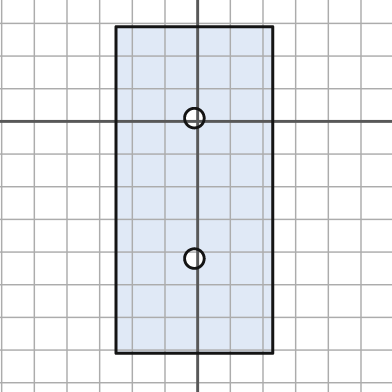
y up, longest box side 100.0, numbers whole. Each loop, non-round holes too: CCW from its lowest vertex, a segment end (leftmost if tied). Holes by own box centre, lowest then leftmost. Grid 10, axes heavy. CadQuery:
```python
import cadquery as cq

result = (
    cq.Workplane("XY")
    .moveTo(-25.0, -71.0)
    .lineTo(23.0, -71.0)
    .lineTo(23.0, 29.0)
    .lineTo(-25.0, 29.0)
    .close()
    .moveTo(-1.0, -42.0)
    .circle(3.0)
    .moveTo(-1.0, 1.0)
    .circle(3.0)
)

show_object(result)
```